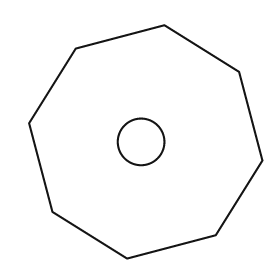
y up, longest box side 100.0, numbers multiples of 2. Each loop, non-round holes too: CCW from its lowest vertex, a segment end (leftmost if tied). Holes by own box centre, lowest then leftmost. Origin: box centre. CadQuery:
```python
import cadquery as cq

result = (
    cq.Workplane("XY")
    .moveTo(-8.0, -50.0)
    .lineTo(30.0, -40.0)
    .lineTo(50.0, -8.0)
    .lineTo(40.0, 30.0)
    .lineTo(8.0, 50.0)
    .lineTo(-30.0, 40.0)
    .lineTo(-50.0, 8.0)
    .lineTo(-40.0, -30.0)
    .close()
    .moveTo(-2.0, 0.0)
    .circle(10.0)
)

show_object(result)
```